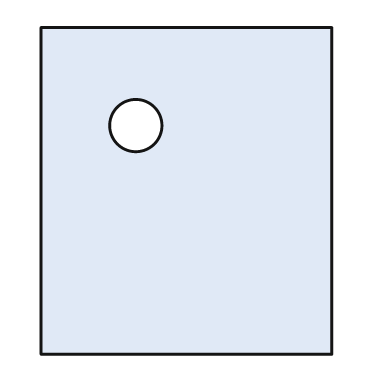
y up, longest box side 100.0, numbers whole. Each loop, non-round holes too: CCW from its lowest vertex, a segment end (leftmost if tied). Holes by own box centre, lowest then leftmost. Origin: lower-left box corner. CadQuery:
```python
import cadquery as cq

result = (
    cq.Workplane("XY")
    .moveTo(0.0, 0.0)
    .lineTo(89.0, 0.0)
    .lineTo(89.0, 100.0)
    .lineTo(0.0, 100.0)
    .close()
    .moveTo(29.0, 70.0)
    .circle(8.0)
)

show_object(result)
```